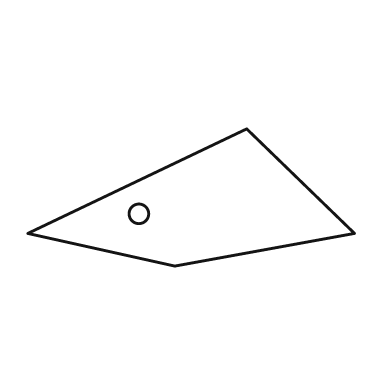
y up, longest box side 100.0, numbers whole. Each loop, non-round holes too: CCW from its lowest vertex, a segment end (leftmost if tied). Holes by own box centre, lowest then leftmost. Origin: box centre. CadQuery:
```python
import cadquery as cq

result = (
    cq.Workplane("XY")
    .moveTo(-5.0, -21.0)
    .lineTo(50.0, -11.0)
    .lineTo(17.0, 21.0)
    .lineTo(-50.0, -11.0)
    .close()
    .moveTo(-16.0, -5.0)
    .circle(3.0)
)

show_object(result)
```